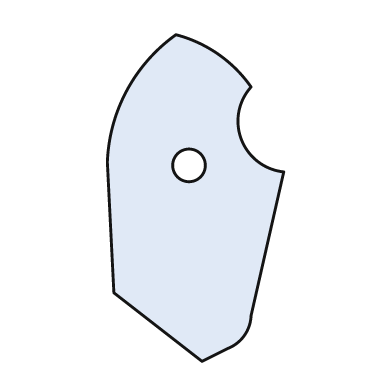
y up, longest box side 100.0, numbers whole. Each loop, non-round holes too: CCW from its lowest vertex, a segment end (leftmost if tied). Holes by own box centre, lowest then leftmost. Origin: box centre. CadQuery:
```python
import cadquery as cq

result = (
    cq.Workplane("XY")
    .moveTo(2.0, -50.0)
    .lineTo(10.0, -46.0)
    .threePointArc((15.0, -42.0), (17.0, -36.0))
    .lineTo(27.0, 8.0)
    .threePointArc((14.0, 18.0), (17.0, 34.0))
    .threePointArc((7.0, 44.0), (-6.0, 50.0))
    .threePointArc((-21.0, 33.0), (-27.0, 11.0))
    .lineTo(-25.0, -29.0)
    .close()
    .moveTo(-2.0, 10.0)
    .circle(5.0)
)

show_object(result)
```